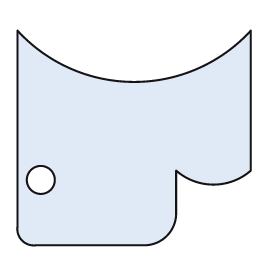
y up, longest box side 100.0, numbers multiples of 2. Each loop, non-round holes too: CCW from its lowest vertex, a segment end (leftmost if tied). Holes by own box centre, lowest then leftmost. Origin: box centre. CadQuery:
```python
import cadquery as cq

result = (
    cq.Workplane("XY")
    .moveTo(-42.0, -46.0)
    .lineTo(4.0, -46.0)
    .threePointArc((14.0, -42.0), (18.0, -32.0))
    .lineTo(18.0, -14.0)
    .threePointArc((34.0, -20.0), (50.0, -14.0))
    .lineTo(50.0, 46.0)
    .threePointArc((0.0, 24.0), (-50.0, 46.0))
    .lineTo(-50.0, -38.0)
    .threePointArc((-48.0, -44.0), (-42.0, -46.0))
    .close()
    .moveTo(-40.0, -18.0)
    .circle(6.0)
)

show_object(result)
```